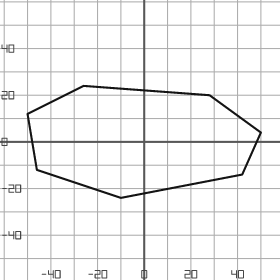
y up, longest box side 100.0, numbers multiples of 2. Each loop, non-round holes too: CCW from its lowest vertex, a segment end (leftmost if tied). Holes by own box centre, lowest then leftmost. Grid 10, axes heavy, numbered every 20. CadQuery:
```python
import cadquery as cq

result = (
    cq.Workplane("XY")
    .moveTo(-10.0, -24.0)
    .lineTo(42.0, -14.0)
    .lineTo(50.0, 4.0)
    .lineTo(28.0, 20.0)
    .lineTo(-26.0, 24.0)
    .lineTo(-50.0, 12.0)
    .lineTo(-46.0, -12.0)
    .close()
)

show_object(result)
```